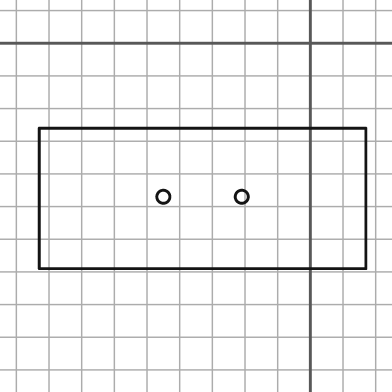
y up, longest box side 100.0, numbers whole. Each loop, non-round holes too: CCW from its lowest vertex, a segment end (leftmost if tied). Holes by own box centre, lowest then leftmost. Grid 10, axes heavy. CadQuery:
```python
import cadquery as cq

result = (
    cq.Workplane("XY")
    .moveTo(-83.0, -69.0)
    .lineTo(17.0, -69.0)
    .lineTo(17.0, -26.0)
    .lineTo(-83.0, -26.0)
    .close()
    .moveTo(-45.0, -47.0)
    .circle(2.0)
    .moveTo(-21.0, -47.0)
    .circle(2.0)
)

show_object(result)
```